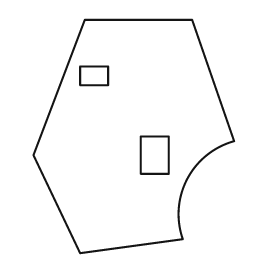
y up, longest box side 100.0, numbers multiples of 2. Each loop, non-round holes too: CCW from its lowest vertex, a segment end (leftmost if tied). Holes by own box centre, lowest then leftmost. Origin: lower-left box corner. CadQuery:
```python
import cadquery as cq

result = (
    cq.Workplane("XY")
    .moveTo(20.0, 0.0)
    .lineTo(64.0, 6.0)
    .threePointArc((66.0, 32.0), (86.0, 48.0))
    .lineTo(68.0, 100.0)
    .lineTo(22.0, 100.0)
    .lineTo(0.0, 42.0)
    .close()
    .moveTo(46.0, 34.0)
    .lineTo(58.0, 34.0)
    .lineTo(58.0, 50.0)
    .lineTo(46.0, 50.0)
    .close()
    .moveTo(20.0, 72.0)
    .lineTo(32.0, 72.0)
    .lineTo(32.0, 80.0)
    .lineTo(20.0, 80.0)
    .close()
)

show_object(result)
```